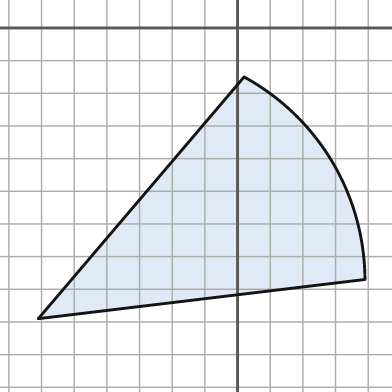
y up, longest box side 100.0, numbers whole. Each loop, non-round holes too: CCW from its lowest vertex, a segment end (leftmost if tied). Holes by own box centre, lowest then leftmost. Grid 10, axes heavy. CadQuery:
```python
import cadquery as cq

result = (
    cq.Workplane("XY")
    .moveTo(-61.0, -89.0)
    .lineTo(39.0, -77.0)
    .threePointArc((29.0, -41.0), (2.0, -15.0))
    .close()
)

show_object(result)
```